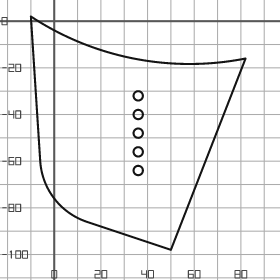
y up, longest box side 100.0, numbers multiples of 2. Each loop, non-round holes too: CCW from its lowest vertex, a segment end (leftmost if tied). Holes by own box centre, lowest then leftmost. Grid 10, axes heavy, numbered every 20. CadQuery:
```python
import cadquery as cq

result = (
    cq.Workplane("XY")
    .moveTo(50.0, -98.0)
    .lineTo(82.0, -16.0)
    .threePointArc((34.0, -16.0), (-10.0, 2.0))
    .lineTo(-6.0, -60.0)
    .threePointArc((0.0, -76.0), (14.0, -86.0))
    .close()
    .moveTo(36.0, -64.0)
    .circle(2.0)
    .moveTo(36.0, -56.0)
    .circle(2.0)
    .moveTo(36.0, -48.0)
    .circle(2.0)
    .moveTo(36.0, -40.0)
    .circle(2.0)
    .moveTo(36.0, -32.0)
    .circle(2.0)
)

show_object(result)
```